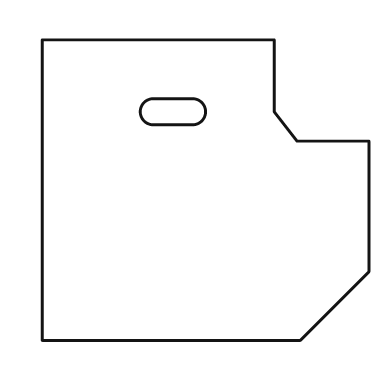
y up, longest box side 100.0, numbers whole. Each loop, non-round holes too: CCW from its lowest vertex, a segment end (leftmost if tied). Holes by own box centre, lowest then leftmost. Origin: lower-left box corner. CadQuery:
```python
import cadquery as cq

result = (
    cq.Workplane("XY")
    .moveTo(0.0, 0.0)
    .lineTo(79.0, 0.0)
    .lineTo(100.0, 21.0)
    .lineTo(100.0, 61.0)
    .lineTo(78.0, 61.0)
    .lineTo(71.0, 70.0)
    .lineTo(71.0, 92.0)
    .lineTo(0.0, 92.0)
    .close()
    .moveTo(34.0, 66.0)
    .lineTo(46.0, 66.0)
    .threePointArc((50.0, 70.0), (46.0, 74.0))
    .lineTo(34.0, 74.0)
    .threePointArc((30.0, 70.0), (34.0, 66.0))
    .close()
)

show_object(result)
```